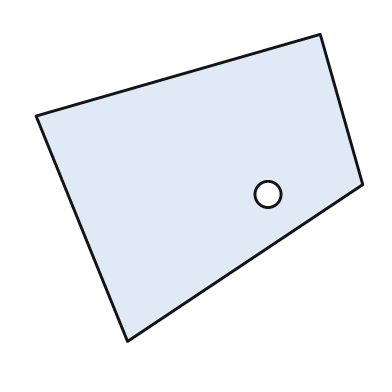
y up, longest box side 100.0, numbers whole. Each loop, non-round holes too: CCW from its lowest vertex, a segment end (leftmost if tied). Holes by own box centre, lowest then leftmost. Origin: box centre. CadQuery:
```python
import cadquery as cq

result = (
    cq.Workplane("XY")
    .moveTo(-22.0, -47.0)
    .lineTo(50.0, 1.0)
    .lineTo(37.0, 47.0)
    .lineTo(-50.0, 22.0)
    .close()
    .moveTo(21.0, -2.0)
    .circle(4.0)
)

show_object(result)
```